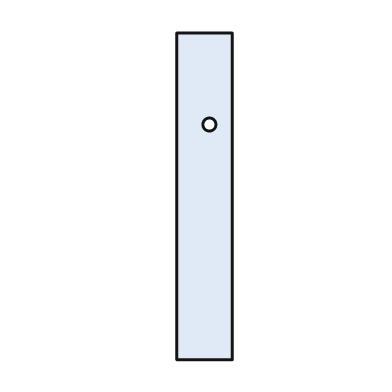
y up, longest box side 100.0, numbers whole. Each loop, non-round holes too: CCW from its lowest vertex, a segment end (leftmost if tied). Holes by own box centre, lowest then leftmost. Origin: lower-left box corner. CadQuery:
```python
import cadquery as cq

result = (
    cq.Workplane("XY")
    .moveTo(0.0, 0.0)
    .lineTo(17.0, 0.0)
    .lineTo(17.0, 100.0)
    .lineTo(0.0, 100.0)
    .close()
    .moveTo(10.0, 72.0)
    .circle(2.0)
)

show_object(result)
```